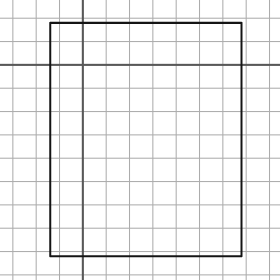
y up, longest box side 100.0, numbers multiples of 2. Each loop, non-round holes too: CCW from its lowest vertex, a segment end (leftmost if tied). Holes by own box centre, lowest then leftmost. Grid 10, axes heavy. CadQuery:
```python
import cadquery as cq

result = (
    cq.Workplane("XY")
    .moveTo(-14.0, -82.0)
    .lineTo(68.0, -82.0)
    .lineTo(68.0, 18.0)
    .lineTo(-14.0, 18.0)
    .close()
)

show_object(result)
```